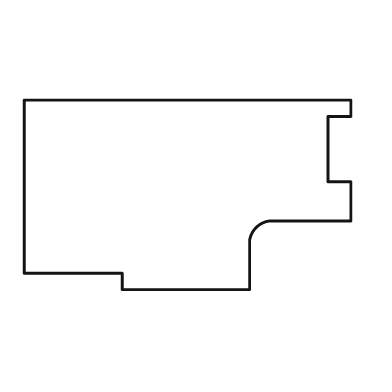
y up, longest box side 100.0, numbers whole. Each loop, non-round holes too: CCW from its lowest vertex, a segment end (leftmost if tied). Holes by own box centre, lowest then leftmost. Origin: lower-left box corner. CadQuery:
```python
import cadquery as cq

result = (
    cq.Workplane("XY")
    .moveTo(30.0, 0.0)
    .lineTo(69.0, 0.0)
    .lineTo(69.0, 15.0)
    .threePointArc((71.0, 19.0), (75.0, 21.0))
    .lineTo(100.0, 21.0)
    .lineTo(100.0, 33.0)
    .lineTo(93.0, 33.0)
    .lineTo(93.0, 53.0)
    .lineTo(100.0, 53.0)
    .lineTo(100.0, 58.0)
    .lineTo(0.0, 58.0)
    .lineTo(0.0, 5.0)
    .lineTo(30.0, 5.0)
    .close()
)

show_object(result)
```